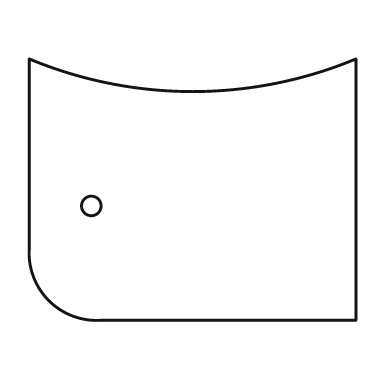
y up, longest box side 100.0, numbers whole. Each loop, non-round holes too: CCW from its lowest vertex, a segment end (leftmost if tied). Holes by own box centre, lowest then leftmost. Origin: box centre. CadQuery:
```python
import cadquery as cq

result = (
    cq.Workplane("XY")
    .moveTo(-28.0, -40.0)
    .lineTo(50.0, -40.0)
    .lineTo(50.0, 40.0)
    .threePointArc((0.0, 30.0), (-50.0, 40.0))
    .lineTo(-50.0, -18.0)
    .threePointArc((-44.0, -34.0), (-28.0, -40.0))
    .close()
    .moveTo(-31.0, -5.0)
    .circle(3.0)
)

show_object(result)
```